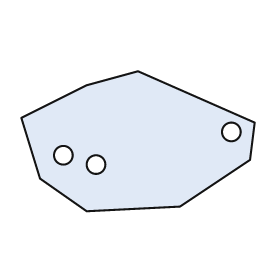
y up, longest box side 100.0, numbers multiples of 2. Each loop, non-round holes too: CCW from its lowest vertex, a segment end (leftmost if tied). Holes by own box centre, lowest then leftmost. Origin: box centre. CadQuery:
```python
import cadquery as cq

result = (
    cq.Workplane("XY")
    .moveTo(-22.0, -30.0)
    .lineTo(18.0, -28.0)
    .lineTo(48.0, -8.0)
    .lineTo(50.0, 8.0)
    .lineTo(0.0, 30.0)
    .lineTo(-22.0, 24.0)
    .lineTo(-50.0, 10.0)
    .lineTo(-42.0, -16.0)
    .close()
    .moveTo(-18.0, -10.0)
    .circle(4.0)
    .moveTo(-32.0, -6.0)
    .circle(4.0)
    .moveTo(40.0, 4.0)
    .circle(4.0)
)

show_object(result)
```